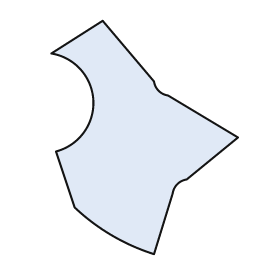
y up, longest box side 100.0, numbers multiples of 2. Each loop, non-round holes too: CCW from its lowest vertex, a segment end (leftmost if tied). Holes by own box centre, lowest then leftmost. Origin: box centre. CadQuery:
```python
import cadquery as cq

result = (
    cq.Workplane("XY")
    .moveTo(4.0, -50.0)
    .lineTo(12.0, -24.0)
    .threePointArc((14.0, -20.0), (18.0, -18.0))
    .lineTo(40.0, 0.0)
    .lineTo(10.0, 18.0)
    .threePointArc((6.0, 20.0), (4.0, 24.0))
    .lineTo(-18.0, 50.0)
    .lineTo(-40.0, 36.0)
    .threePointArc((-22.0, 16.0), (-38.0, -6.0))
    .lineTo(-30.0, -30.0)
    .threePointArc((-14.0, -42.0), (4.0, -50.0))
    .close()
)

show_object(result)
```